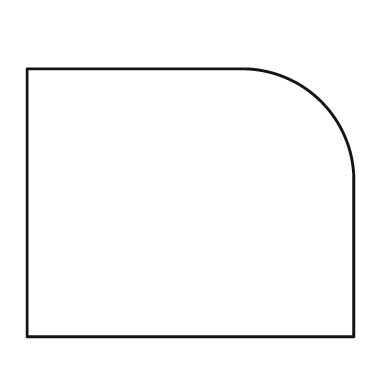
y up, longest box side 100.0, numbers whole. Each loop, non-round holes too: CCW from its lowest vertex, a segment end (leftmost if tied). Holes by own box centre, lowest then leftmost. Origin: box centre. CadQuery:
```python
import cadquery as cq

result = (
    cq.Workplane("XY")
    .moveTo(-50.0, -41.0)
    .lineTo(50.0, -41.0)
    .lineTo(50.0, 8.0)
    .threePointArc((40.0, 31.0), (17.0, 41.0))
    .lineTo(-50.0, 41.0)
    .close()
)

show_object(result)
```